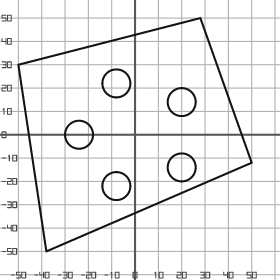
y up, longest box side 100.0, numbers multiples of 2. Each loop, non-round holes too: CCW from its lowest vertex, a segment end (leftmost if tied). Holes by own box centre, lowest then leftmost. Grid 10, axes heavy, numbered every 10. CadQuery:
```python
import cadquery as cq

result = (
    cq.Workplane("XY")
    .moveTo(-38.0, -50.0)
    .lineTo(50.0, -12.0)
    .lineTo(28.0, 50.0)
    .lineTo(-50.0, 30.0)
    .close()
    .moveTo(-8.0, -22.0)
    .circle(6.0)
    .moveTo(20.0, -14.0)
    .circle(6.0)
    .moveTo(-24.0, 0.0)
    .circle(6.0)
    .moveTo(20.0, 14.0)
    .circle(6.0)
    .moveTo(-8.0, 22.0)
    .circle(6.0)
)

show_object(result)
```